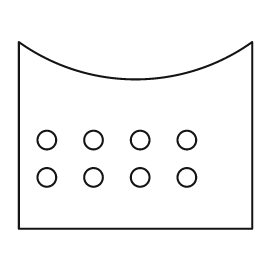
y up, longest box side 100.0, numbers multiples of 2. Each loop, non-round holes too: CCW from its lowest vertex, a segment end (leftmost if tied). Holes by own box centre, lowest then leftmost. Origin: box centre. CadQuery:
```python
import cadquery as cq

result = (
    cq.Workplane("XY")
    .moveTo(-50.0, -40.0)
    .lineTo(50.0, -40.0)
    .lineTo(50.0, 40.0)
    .threePointArc((0.0, 24.0), (-50.0, 40.0))
    .close()
    .moveTo(-38.0, -18.0)
    .circle(4.0)
    .moveTo(-18.0, -18.0)
    .circle(4.0)
    .moveTo(2.0, -18.0)
    .circle(4.0)
    .moveTo(22.0, -18.0)
    .circle(4.0)
    .moveTo(-38.0, -2.0)
    .circle(4.0)
    .moveTo(-18.0, -2.0)
    .circle(4.0)
    .moveTo(2.0, -2.0)
    .circle(4.0)
    .moveTo(22.0, -2.0)
    .circle(4.0)
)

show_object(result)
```